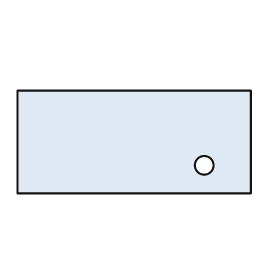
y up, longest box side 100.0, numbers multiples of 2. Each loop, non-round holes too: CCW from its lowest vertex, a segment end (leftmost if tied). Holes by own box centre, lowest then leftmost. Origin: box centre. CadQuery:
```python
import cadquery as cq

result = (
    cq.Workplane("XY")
    .moveTo(-50.0, -22.0)
    .lineTo(50.0, -22.0)
    .lineTo(50.0, 22.0)
    .lineTo(-50.0, 22.0)
    .close()
    .moveTo(30.0, -10.0)
    .circle(4.0)
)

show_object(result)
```